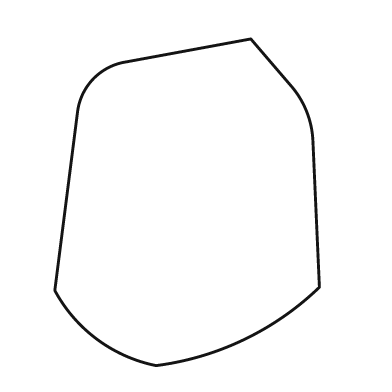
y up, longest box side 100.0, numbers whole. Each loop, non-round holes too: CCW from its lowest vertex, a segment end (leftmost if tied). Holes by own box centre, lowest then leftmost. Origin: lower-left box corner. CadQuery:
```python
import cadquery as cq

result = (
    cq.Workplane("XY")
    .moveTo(31.0, 0.0)
    .threePointArc((58.0, 8.0), (81.0, 24.0))
    .lineTo(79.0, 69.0)
    .threePointArc((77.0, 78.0), (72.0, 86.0))
    .lineTo(60.0, 100.0)
    .lineTo(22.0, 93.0)
    .threePointArc((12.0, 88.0), (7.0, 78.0))
    .lineTo(0.0, 23.0)
    .threePointArc((13.0, 8.0), (31.0, 0.0))
    .close()
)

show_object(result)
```